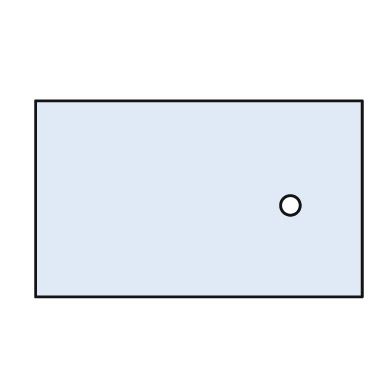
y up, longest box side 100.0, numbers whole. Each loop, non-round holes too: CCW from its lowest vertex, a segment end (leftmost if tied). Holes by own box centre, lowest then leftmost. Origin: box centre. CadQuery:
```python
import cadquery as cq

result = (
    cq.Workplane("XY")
    .moveTo(-50.0, -30.0)
    .lineTo(50.0, -30.0)
    .lineTo(50.0, 30.0)
    .lineTo(-50.0, 30.0)
    .close()
    .moveTo(28.0, -2.0)
    .circle(3.0)
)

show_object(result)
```